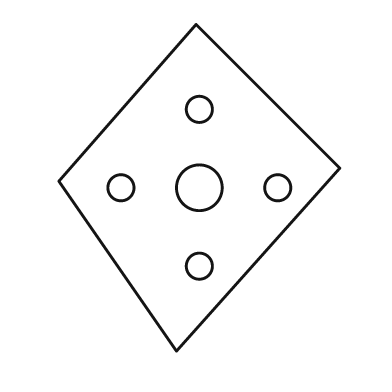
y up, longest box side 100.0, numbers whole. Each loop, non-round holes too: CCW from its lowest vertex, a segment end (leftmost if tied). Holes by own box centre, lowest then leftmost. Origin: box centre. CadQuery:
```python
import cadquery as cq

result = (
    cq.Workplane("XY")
    .moveTo(-7.0, -50.0)
    .lineTo(43.0, 6.0)
    .lineTo(-1.0, 50.0)
    .lineTo(-43.0, 2.0)
    .close()
    .moveTo(0.0, -24.0)
    .circle(4.0)
    .moveTo(-24.0, 0.0)
    .circle(4.0)
    .moveTo(0.0, 0.0)
    .circle(7.0)
    .moveTo(24.0, 0.0)
    .circle(4.0)
    .moveTo(0.0, 24.0)
    .circle(4.0)
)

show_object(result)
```